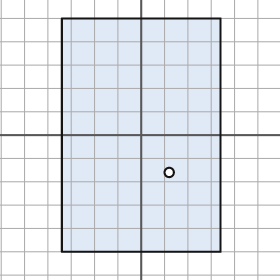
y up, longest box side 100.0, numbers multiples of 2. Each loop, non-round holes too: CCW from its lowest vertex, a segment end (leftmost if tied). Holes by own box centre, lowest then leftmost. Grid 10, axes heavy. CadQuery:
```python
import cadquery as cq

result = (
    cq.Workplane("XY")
    .moveTo(-34.0, -50.0)
    .lineTo(34.0, -50.0)
    .lineTo(34.0, 50.0)
    .lineTo(-34.0, 50.0)
    .close()
    .moveTo(12.0, -16.0)
    .circle(2.0)
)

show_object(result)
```